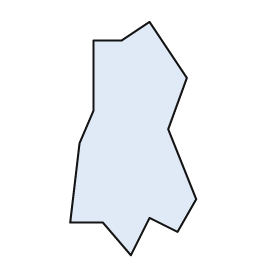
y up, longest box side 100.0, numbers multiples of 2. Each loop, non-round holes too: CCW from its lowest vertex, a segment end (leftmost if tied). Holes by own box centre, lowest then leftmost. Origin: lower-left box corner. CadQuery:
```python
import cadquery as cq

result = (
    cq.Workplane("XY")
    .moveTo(26.0, 0.0)
    .lineTo(34.0, 16.0)
    .lineTo(46.0, 10.0)
    .lineTo(54.0, 24.0)
    .lineTo(42.0, 54.0)
    .lineTo(50.0, 76.0)
    .lineTo(34.0, 100.0)
    .lineTo(22.0, 92.0)
    .lineTo(10.0, 92.0)
    .lineTo(10.0, 62.0)
    .lineTo(4.0, 48.0)
    .lineTo(0.0, 14.0)
    .lineTo(14.0, 14.0)
    .close()
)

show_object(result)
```